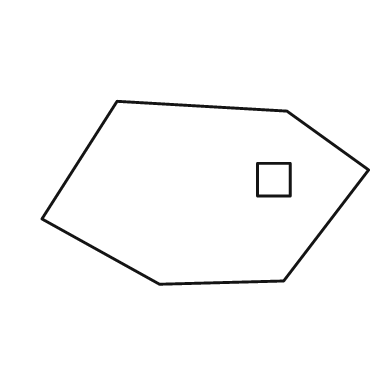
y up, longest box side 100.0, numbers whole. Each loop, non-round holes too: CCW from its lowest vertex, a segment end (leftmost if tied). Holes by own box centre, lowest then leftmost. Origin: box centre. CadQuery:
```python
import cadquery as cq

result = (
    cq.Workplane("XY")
    .moveTo(-14.0, -28.0)
    .lineTo(24.0, -27.0)
    .lineTo(50.0, 7.0)
    .lineTo(25.0, 25.0)
    .lineTo(-27.0, 28.0)
    .lineTo(-50.0, -8.0)
    .close()
    .moveTo(16.0, -1.0)
    .lineTo(26.0, -1.0)
    .lineTo(26.0, 9.0)
    .lineTo(16.0, 9.0)
    .close()
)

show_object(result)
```